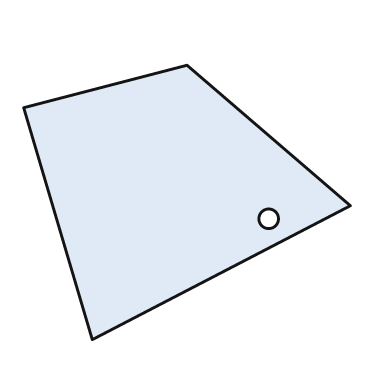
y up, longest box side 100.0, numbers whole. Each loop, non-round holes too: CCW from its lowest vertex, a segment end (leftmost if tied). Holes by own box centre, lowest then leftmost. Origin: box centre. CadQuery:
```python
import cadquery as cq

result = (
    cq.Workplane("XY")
    .moveTo(-29.0, -42.0)
    .lineTo(50.0, -1.0)
    .lineTo(0.0, 42.0)
    .lineTo(-50.0, 29.0)
    .close()
    .moveTo(25.0, -5.0)
    .circle(3.0)
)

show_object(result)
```